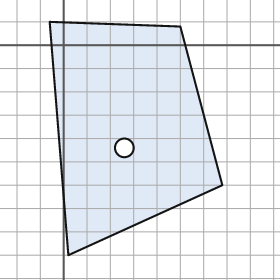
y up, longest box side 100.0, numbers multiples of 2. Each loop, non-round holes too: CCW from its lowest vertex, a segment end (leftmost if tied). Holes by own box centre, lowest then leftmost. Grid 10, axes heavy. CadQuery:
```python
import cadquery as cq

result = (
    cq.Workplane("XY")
    .moveTo(2.0, -90.0)
    .lineTo(68.0, -60.0)
    .lineTo(50.0, 8.0)
    .lineTo(-6.0, 10.0)
    .close()
    .moveTo(26.0, -44.0)
    .circle(4.0)
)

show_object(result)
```